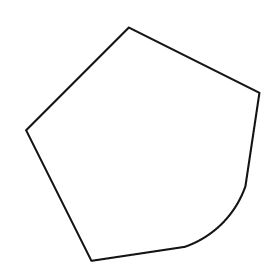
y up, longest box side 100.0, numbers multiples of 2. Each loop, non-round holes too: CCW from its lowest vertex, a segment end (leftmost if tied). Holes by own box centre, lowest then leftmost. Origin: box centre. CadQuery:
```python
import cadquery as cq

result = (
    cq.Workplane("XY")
    .moveTo(-22.0, -50.0)
    .lineTo(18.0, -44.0)
    .threePointArc((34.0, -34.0), (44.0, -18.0))
    .lineTo(50.0, 22.0)
    .lineTo(-6.0, 50.0)
    .lineTo(-50.0, 6.0)
    .close()
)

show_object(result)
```